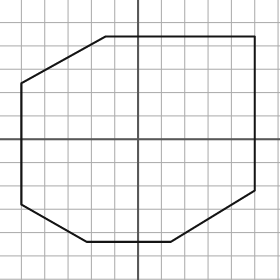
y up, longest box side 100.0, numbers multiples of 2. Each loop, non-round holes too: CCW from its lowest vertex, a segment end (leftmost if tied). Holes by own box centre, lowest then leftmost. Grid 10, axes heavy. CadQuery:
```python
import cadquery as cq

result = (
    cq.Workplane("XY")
    .moveTo(-22.0, -44.0)
    .lineTo(14.0, -44.0)
    .lineTo(50.0, -22.0)
    .lineTo(50.0, 44.0)
    .lineTo(-14.0, 44.0)
    .lineTo(-50.0, 24.0)
    .lineTo(-50.0, -28.0)
    .close()
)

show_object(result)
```